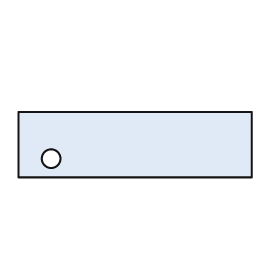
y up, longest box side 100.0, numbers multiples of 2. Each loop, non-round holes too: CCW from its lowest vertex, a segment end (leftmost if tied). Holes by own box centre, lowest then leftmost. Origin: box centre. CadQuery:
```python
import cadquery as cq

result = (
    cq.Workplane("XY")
    .moveTo(-50.0, -14.0)
    .lineTo(50.0, -14.0)
    .lineTo(50.0, 14.0)
    .lineTo(-50.0, 14.0)
    .close()
    .moveTo(-36.0, -6.0)
    .circle(4.0)
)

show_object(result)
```